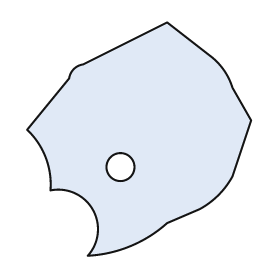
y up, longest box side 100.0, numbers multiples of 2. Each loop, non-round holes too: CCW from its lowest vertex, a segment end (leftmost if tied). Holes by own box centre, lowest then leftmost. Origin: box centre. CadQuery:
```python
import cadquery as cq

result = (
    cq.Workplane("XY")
    .moveTo(-22.0, -50.0)
    .threePointArc((-4.0, -46.0), (12.0, -36.0))
    .lineTo(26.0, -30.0)
    .threePointArc((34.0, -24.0), (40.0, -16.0))
    .lineTo(48.0, 8.0)
    .lineTo(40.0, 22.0)
    .threePointArc((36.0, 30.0), (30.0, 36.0))
    .lineTo(12.0, 50.0)
    .lineTo(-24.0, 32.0)
    .threePointArc((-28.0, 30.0), (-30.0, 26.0))
    .lineTo(-48.0, 4.0)
    .threePointArc((-40.0, -8.0), (-38.0, -22.0))
    .threePointArc((-20.0, -30.0), (-22.0, -50.0))
    .close()
    .moveTo(-8.0, -12.0)
    .circle(6.0)
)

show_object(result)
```